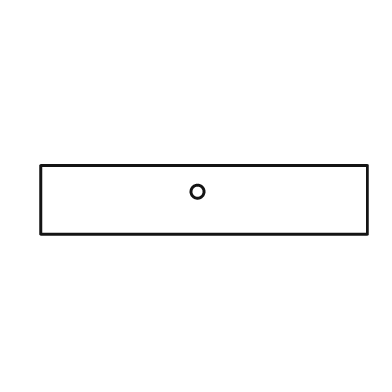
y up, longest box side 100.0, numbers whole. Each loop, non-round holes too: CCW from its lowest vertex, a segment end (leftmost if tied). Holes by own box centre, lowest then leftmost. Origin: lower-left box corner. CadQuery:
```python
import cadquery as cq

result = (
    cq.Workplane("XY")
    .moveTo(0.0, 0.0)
    .lineTo(100.0, 0.0)
    .lineTo(100.0, 21.0)
    .lineTo(0.0, 21.0)
    .close()
    .moveTo(48.0, 13.0)
    .circle(2.0)
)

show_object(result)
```